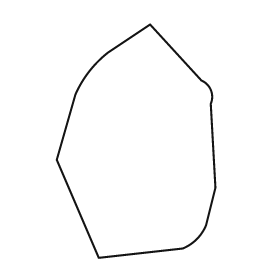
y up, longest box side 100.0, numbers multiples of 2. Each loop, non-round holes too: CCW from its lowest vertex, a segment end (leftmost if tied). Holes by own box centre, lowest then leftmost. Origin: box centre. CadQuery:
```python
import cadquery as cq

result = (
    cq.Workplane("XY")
    .moveTo(-16.0, -50.0)
    .lineTo(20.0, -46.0)
    .threePointArc((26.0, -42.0), (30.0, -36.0))
    .lineTo(34.0, -20.0)
    .lineTo(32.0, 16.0)
    .threePointArc((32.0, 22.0), (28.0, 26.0))
    .lineTo(6.0, 50.0)
    .lineTo(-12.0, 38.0)
    .threePointArc((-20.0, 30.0), (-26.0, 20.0))
    .lineTo(-34.0, -8.0)
    .close()
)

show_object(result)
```